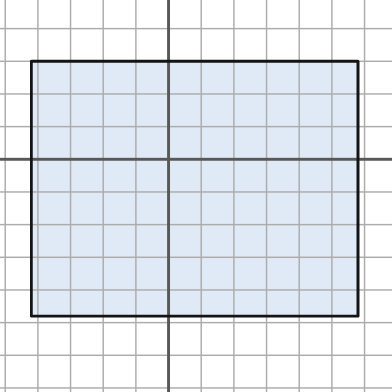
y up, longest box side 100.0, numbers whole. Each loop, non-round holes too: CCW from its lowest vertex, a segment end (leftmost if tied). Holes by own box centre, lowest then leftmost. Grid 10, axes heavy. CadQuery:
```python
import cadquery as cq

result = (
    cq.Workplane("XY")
    .moveTo(-42.0, -48.0)
    .lineTo(58.0, -48.0)
    .lineTo(58.0, 30.0)
    .lineTo(-42.0, 30.0)
    .close()
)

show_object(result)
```